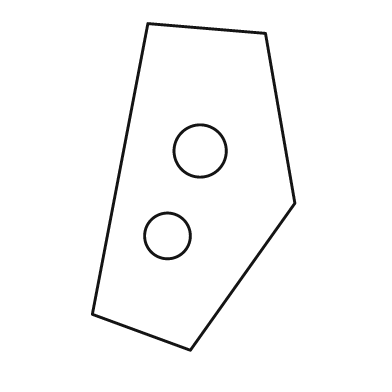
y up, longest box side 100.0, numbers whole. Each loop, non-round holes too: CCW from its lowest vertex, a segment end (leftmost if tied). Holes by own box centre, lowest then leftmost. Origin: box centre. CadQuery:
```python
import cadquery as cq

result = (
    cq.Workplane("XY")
    .moveTo(-1.0, -50.0)
    .lineTo(31.0, -5.0)
    .lineTo(22.0, 47.0)
    .lineTo(-14.0, 50.0)
    .lineTo(-31.0, -39.0)
    .close()
    .moveTo(-8.0, -15.0)
    .circle(7.0)
    .moveTo(2.0, 11.0)
    .circle(8.0)
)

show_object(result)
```